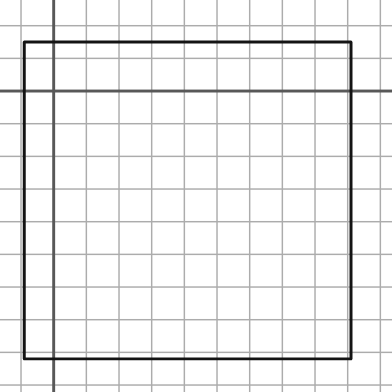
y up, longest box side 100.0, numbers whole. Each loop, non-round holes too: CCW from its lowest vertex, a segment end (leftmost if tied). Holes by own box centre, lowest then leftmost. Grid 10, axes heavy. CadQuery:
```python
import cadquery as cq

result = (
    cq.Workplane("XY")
    .moveTo(-9.0, -82.0)
    .lineTo(91.0, -82.0)
    .lineTo(91.0, 15.0)
    .lineTo(-9.0, 15.0)
    .close()
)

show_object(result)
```